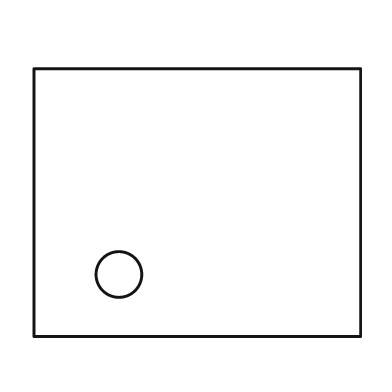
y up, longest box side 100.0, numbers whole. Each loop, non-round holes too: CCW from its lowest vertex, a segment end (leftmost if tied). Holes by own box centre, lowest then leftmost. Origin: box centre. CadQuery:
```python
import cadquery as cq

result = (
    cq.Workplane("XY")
    .moveTo(-50.0, -41.0)
    .lineTo(50.0, -41.0)
    .lineTo(50.0, 41.0)
    .lineTo(-50.0, 41.0)
    .close()
    .moveTo(-24.0, -22.0)
    .circle(7.0)
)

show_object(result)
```